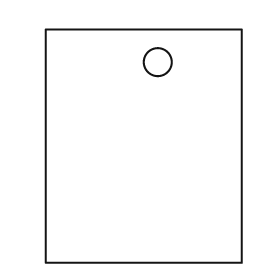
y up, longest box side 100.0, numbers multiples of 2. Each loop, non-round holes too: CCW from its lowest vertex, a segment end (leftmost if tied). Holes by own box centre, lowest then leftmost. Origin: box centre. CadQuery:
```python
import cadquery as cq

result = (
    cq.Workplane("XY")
    .moveTo(-42.0, -50.0)
    .lineTo(42.0, -50.0)
    .lineTo(42.0, 50.0)
    .lineTo(-42.0, 50.0)
    .close()
    .moveTo(6.0, 36.0)
    .circle(6.0)
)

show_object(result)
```